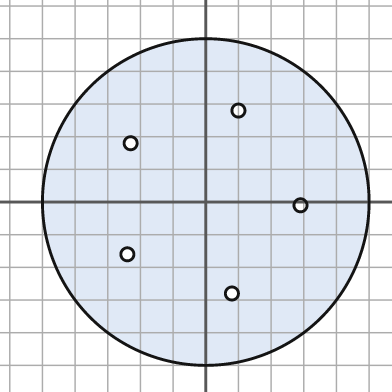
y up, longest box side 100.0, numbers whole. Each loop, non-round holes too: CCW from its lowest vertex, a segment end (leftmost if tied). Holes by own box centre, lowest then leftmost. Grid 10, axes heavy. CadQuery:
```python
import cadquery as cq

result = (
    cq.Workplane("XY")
    .moveTo(0.0, 0.0)
    .circle(50.0)
    .moveTo(8.0, -28.0)
    .circle(2.0)
    .moveTo(-24.0, -16.0)
    .circle(2.0)
    .moveTo(29.0, -1.0)
    .circle(2.0)
    .moveTo(-23.0, 18.0)
    .circle(2.0)
    .moveTo(10.0, 28.0)
    .circle(2.0)
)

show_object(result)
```